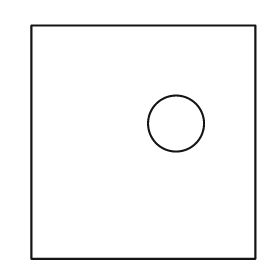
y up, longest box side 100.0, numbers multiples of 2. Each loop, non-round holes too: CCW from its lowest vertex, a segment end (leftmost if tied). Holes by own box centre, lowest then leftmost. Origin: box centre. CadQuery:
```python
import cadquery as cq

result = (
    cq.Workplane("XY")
    .moveTo(-48.0, -50.0)
    .lineTo(48.0, -50.0)
    .lineTo(48.0, 50.0)
    .lineTo(-48.0, 50.0)
    .close()
    .moveTo(14.0, 8.0)
    .circle(12.0)
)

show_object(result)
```